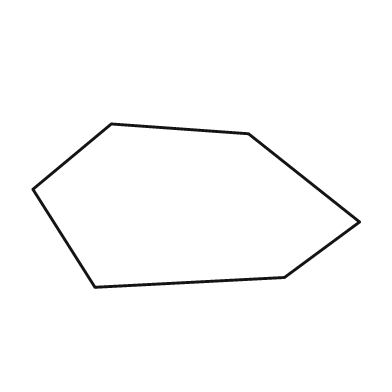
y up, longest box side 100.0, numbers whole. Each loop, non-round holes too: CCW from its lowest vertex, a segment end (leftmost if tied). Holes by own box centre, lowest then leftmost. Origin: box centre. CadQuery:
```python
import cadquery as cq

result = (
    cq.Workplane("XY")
    .moveTo(-31.0, -25.0)
    .lineTo(27.0, -22.0)
    .lineTo(50.0, -5.0)
    .lineTo(16.0, 22.0)
    .lineTo(-26.0, 25.0)
    .lineTo(-50.0, 5.0)
    .close()
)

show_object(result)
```